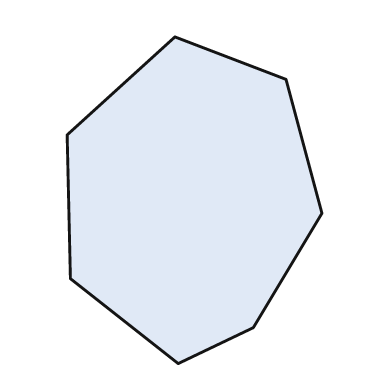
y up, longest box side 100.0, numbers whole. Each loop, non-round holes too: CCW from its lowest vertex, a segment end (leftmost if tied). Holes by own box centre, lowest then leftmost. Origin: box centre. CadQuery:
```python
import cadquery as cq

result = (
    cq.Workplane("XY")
    .moveTo(-5.0, -50.0)
    .lineTo(18.0, -39.0)
    .lineTo(39.0, -4.0)
    .lineTo(28.0, 37.0)
    .lineTo(-6.0, 50.0)
    .lineTo(-39.0, 20.0)
    .lineTo(-38.0, -24.0)
    .close()
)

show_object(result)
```